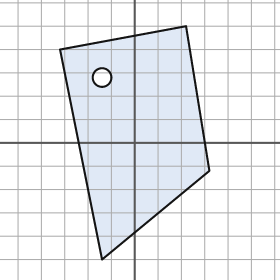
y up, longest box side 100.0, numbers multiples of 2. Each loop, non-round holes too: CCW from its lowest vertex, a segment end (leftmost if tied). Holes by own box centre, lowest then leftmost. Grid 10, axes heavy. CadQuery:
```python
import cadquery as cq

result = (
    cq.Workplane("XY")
    .moveTo(-14.0, -50.0)
    .lineTo(32.0, -12.0)
    .lineTo(22.0, 50.0)
    .lineTo(-32.0, 40.0)
    .close()
    .moveTo(-14.0, 28.0)
    .circle(4.0)
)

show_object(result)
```